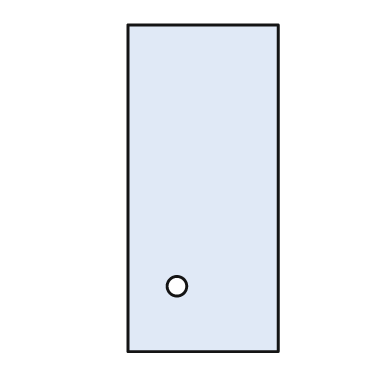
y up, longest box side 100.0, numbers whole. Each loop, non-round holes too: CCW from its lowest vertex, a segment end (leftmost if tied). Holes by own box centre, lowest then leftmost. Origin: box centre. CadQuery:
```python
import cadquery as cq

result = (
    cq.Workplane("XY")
    .moveTo(-23.0, -50.0)
    .lineTo(23.0, -50.0)
    .lineTo(23.0, 50.0)
    .lineTo(-23.0, 50.0)
    .close()
    .moveTo(-8.0, -30.0)
    .circle(3.0)
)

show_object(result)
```